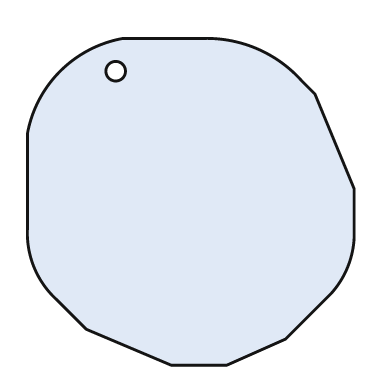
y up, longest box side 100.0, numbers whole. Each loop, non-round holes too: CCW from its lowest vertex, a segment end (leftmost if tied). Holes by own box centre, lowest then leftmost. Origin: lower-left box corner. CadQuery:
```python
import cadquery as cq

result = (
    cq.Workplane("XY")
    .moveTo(44.0, 0.0)
    .lineTo(61.0, 0.0)
    .lineTo(79.0, 8.0)
    .lineTo(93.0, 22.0)
    .threePointArc((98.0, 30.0), (100.0, 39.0))
    .lineTo(100.0, 54.0)
    .lineTo(88.0, 83.0)
    .lineTo(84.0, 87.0)
    .threePointArc((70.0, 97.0), (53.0, 100.0))
    .lineTo(29.0, 100.0)
    .threePointArc((10.0, 90.0), (0.0, 71.0))
    .lineTo(0.0, 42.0)
    .threePointArc((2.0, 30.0), (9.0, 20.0))
    .lineTo(18.0, 11.0)
    .close()
    .moveTo(27.0, 90.0)
    .circle(3.0)
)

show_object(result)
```